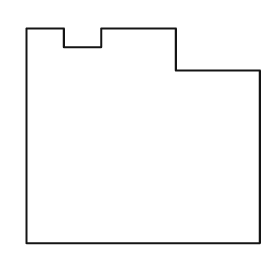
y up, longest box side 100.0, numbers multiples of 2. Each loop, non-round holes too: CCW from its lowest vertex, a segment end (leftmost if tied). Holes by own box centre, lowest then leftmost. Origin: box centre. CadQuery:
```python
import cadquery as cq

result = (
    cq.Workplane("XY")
    .moveTo(-50.0, -46.0)
    .lineTo(50.0, -46.0)
    .lineTo(50.0, 28.0)
    .lineTo(14.0, 28.0)
    .lineTo(14.0, 46.0)
    .lineTo(-18.0, 46.0)
    .lineTo(-18.0, 38.0)
    .lineTo(-34.0, 38.0)
    .lineTo(-34.0, 46.0)
    .lineTo(-50.0, 46.0)
    .close()
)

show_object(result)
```